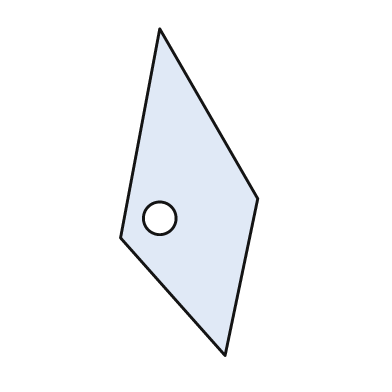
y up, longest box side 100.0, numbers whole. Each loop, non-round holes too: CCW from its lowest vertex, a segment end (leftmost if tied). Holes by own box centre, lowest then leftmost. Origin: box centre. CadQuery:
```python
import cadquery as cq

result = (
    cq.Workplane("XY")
    .moveTo(11.0, -50.0)
    .lineTo(21.0, -2.0)
    .lineTo(-9.0, 50.0)
    .lineTo(-21.0, -14.0)
    .close()
    .moveTo(-9.0, -8.0)
    .circle(5.0)
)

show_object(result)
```